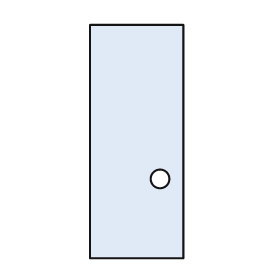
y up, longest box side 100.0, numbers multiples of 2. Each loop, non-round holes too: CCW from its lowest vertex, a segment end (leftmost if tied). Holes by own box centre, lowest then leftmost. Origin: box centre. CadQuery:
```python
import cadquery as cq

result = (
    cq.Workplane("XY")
    .moveTo(-20.0, -50.0)
    .lineTo(20.0, -50.0)
    .lineTo(20.0, 50.0)
    .lineTo(-20.0, 50.0)
    .close()
    .moveTo(10.0, -16.0)
    .circle(4.0)
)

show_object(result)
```